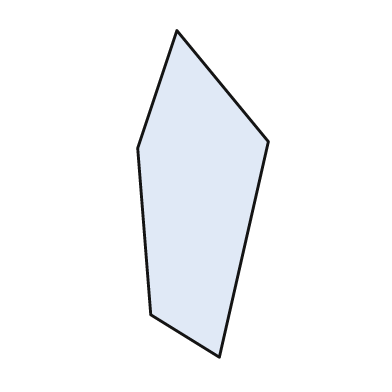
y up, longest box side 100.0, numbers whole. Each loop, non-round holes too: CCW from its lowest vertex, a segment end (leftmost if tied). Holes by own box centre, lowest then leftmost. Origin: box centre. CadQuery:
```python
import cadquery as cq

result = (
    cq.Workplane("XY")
    .moveTo(5.0, -50.0)
    .lineTo(20.0, 16.0)
    .lineTo(-8.0, 50.0)
    .lineTo(-20.0, 14.0)
    .lineTo(-16.0, -37.0)
    .close()
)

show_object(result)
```